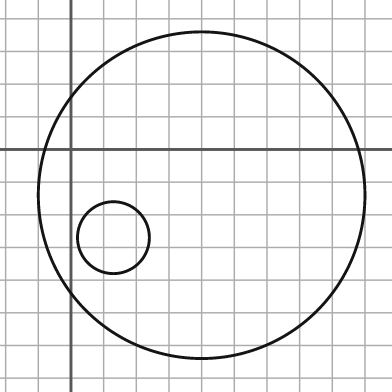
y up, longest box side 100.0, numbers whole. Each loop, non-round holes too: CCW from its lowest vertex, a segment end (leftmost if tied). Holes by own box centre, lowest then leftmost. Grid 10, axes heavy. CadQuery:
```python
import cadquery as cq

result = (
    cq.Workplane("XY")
    .moveTo(40.0, -14.0)
    .circle(50.0)
    .moveTo(13.0, -27.0)
    .circle(11.0)
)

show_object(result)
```